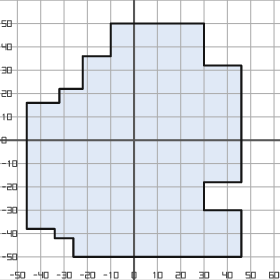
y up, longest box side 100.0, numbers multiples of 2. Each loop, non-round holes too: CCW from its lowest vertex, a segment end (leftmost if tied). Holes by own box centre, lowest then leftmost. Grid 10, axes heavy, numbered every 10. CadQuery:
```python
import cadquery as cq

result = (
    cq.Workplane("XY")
    .moveTo(-26.0, -50.0)
    .lineTo(46.0, -50.0)
    .lineTo(46.0, -30.0)
    .lineTo(30.0, -30.0)
    .lineTo(30.0, -18.0)
    .lineTo(46.0, -18.0)
    .lineTo(46.0, 32.0)
    .lineTo(30.0, 32.0)
    .lineTo(30.0, 50.0)
    .lineTo(-10.0, 50.0)
    .lineTo(-10.0, 36.0)
    .lineTo(-22.0, 36.0)
    .lineTo(-22.0, 22.0)
    .lineTo(-32.0, 22.0)
    .lineTo(-32.0, 16.0)
    .lineTo(-46.0, 16.0)
    .lineTo(-46.0, -38.0)
    .lineTo(-34.0, -38.0)
    .lineTo(-34.0, -42.0)
    .lineTo(-26.0, -42.0)
    .close()
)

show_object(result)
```